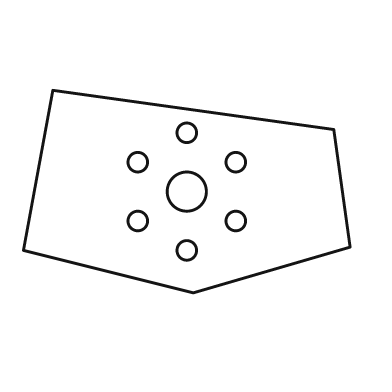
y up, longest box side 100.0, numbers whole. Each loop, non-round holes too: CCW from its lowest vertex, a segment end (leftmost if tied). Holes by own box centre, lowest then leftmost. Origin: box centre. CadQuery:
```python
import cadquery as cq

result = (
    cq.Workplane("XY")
    .moveTo(2.0, -31.0)
    .lineTo(50.0, -17.0)
    .lineTo(45.0, 19.0)
    .lineTo(-41.0, 31.0)
    .lineTo(-50.0, -18.0)
    .close()
    .moveTo(0.0, -18.0)
    .circle(3.0)
    .moveTo(-15.0, -9.0)
    .circle(3.0)
    .moveTo(15.0, -9.0)
    .circle(3.0)
    .moveTo(0.0, 0.0)
    .circle(6.0)
    .moveTo(-15.0, 9.0)
    .circle(3.0)
    .moveTo(15.0, 9.0)
    .circle(3.0)
    .moveTo(0.0, 18.0)
    .circle(3.0)
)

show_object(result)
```